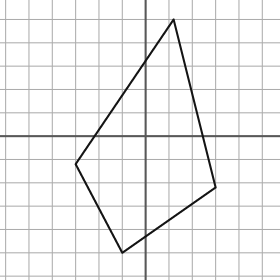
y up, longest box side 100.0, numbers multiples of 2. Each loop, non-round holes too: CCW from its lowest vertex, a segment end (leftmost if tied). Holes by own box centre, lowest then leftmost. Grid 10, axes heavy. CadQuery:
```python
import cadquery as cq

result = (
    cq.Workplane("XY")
    .moveTo(-10.0, -50.0)
    .lineTo(30.0, -22.0)
    .lineTo(12.0, 50.0)
    .lineTo(-30.0, -12.0)
    .close()
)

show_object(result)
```